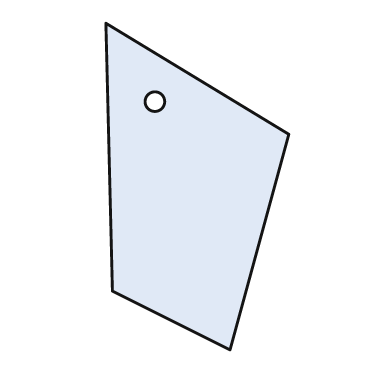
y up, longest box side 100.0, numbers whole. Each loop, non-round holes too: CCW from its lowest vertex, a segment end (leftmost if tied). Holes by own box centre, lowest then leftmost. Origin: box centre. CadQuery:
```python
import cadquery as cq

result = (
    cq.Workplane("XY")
    .moveTo(10.0, -50.0)
    .lineTo(28.0, 16.0)
    .lineTo(-28.0, 50.0)
    .lineTo(-26.0, -32.0)
    .close()
    .moveTo(-13.0, 26.0)
    .circle(3.0)
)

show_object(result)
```